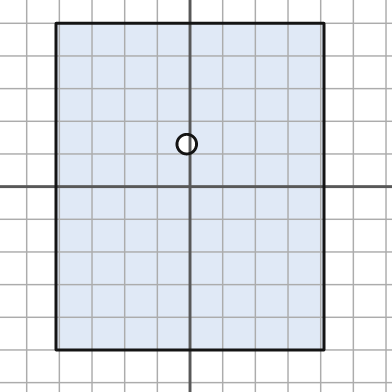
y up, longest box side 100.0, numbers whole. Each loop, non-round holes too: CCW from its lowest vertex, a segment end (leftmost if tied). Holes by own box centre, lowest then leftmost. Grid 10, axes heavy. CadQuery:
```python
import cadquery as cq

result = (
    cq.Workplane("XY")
    .moveTo(-41.0, -50.0)
    .lineTo(41.0, -50.0)
    .lineTo(41.0, 50.0)
    .lineTo(-41.0, 50.0)
    .close()
    .moveTo(-1.0, 13.0)
    .circle(3.0)
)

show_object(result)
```